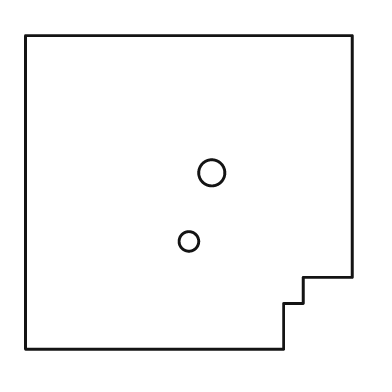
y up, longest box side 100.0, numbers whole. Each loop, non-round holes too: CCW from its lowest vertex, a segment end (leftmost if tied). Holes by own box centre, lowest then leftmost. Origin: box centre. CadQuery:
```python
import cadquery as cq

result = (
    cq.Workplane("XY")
    .moveTo(-50.0, -48.0)
    .lineTo(29.0, -48.0)
    .lineTo(29.0, -34.0)
    .lineTo(35.0, -34.0)
    .lineTo(35.0, -26.0)
    .lineTo(50.0, -26.0)
    .lineTo(50.0, 48.0)
    .lineTo(-50.0, 48.0)
    .close()
    .moveTo(0.0, -15.0)
    .circle(3.0)
    .moveTo(7.0, 6.0)
    .circle(4.0)
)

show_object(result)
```